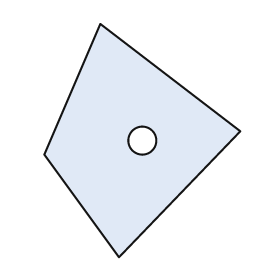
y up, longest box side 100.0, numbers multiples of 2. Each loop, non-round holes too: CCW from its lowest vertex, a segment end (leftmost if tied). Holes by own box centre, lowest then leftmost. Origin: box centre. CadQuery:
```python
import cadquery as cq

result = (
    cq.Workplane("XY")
    .moveTo(-10.0, -50.0)
    .lineTo(42.0, 4.0)
    .lineTo(-18.0, 50.0)
    .lineTo(-42.0, -6.0)
    .close()
    .moveTo(0.0, 0.0)
    .circle(6.0)
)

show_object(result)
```